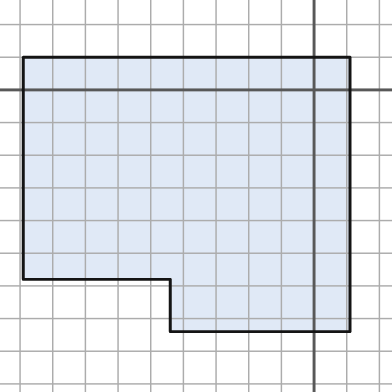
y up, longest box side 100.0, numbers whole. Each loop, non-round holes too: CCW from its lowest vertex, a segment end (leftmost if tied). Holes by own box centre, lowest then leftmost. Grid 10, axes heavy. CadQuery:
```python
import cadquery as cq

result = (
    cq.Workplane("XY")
    .moveTo(-44.0, -74.0)
    .lineTo(11.0, -74.0)
    .lineTo(11.0, 10.0)
    .lineTo(-89.0, 10.0)
    .lineTo(-89.0, -58.0)
    .lineTo(-44.0, -58.0)
    .close()
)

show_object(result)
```